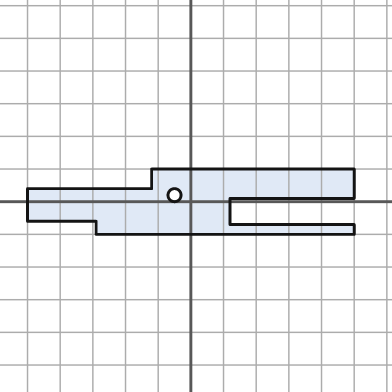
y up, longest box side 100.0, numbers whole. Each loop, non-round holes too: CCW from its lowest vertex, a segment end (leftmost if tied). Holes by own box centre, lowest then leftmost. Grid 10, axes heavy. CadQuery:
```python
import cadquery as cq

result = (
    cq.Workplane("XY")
    .moveTo(-29.0, -10.0)
    .lineTo(50.0, -10.0)
    .lineTo(50.0, -7.0)
    .lineTo(12.0, -7.0)
    .lineTo(12.0, 1.0)
    .lineTo(50.0, 1.0)
    .lineTo(50.0, 10.0)
    .lineTo(-12.0, 10.0)
    .lineTo(-12.0, 4.0)
    .lineTo(-50.0, 4.0)
    .lineTo(-50.0, -6.0)
    .lineTo(-29.0, -6.0)
    .close()
    .moveTo(-5.0, 2.0)
    .circle(2.0)
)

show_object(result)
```